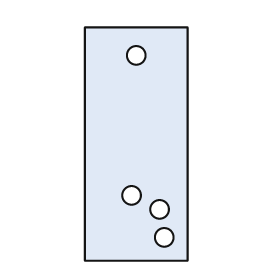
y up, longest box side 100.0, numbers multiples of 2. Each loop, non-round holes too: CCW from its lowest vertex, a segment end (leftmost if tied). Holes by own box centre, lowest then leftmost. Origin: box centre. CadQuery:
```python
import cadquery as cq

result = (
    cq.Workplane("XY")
    .moveTo(-22.0, -50.0)
    .lineTo(22.0, -50.0)
    .lineTo(22.0, 50.0)
    .lineTo(-22.0, 50.0)
    .close()
    .moveTo(12.0, -40.0)
    .circle(4.0)
    .moveTo(10.0, -28.0)
    .circle(4.0)
    .moveTo(-2.0, -22.0)
    .circle(4.0)
    .moveTo(0.0, 38.0)
    .circle(4.0)
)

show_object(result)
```